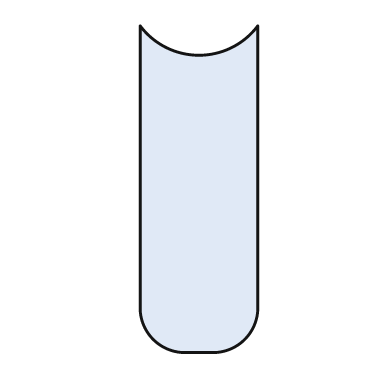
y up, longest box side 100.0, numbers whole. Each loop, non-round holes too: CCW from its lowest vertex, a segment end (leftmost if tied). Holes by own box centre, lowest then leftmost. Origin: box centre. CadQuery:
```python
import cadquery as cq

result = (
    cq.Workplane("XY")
    .moveTo(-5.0, -50.0)
    .lineTo(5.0, -50.0)
    .threePointArc((14.0, -46.0), (18.0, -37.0))
    .lineTo(18.0, 50.0)
    .threePointArc((0.0, 41.0), (-18.0, 50.0))
    .lineTo(-18.0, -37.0)
    .threePointArc((-14.0, -46.0), (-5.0, -50.0))
    .close()
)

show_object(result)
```